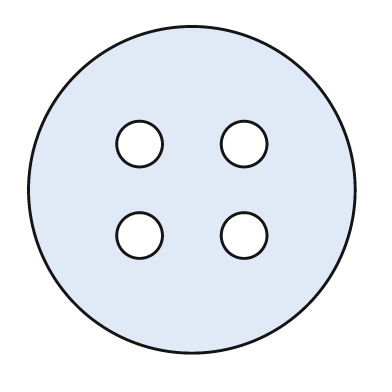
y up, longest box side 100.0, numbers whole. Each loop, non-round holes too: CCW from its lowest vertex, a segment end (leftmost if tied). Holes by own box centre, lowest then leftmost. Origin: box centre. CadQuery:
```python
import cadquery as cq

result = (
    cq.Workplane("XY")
    .moveTo(0.0, 0.0)
    .circle(50.0)
    .moveTo(-16.0, -14.0)
    .circle(7.0)
    .moveTo(16.0, -14.0)
    .circle(7.0)
    .moveTo(-16.0, 14.0)
    .circle(7.0)
    .moveTo(16.0, 14.0)
    .circle(7.0)
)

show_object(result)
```